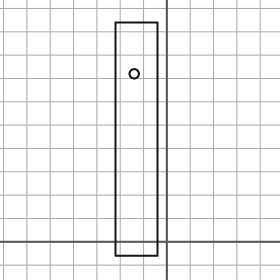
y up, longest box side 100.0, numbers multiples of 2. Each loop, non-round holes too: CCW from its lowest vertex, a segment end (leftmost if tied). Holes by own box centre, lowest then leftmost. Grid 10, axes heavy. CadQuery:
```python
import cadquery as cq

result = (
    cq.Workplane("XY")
    .moveTo(-22.0, -6.0)
    .lineTo(-4.0, -6.0)
    .lineTo(-4.0, 94.0)
    .lineTo(-22.0, 94.0)
    .close()
    .moveTo(-14.0, 72.0)
    .circle(2.0)
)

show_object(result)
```